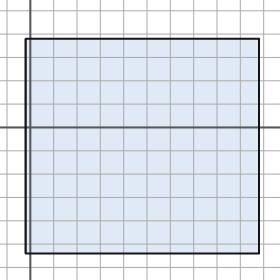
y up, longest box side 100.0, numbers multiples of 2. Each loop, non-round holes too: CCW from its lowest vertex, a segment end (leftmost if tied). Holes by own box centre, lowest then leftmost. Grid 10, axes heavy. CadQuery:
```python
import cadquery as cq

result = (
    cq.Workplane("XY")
    .moveTo(-2.0, -54.0)
    .lineTo(98.0, -54.0)
    .lineTo(98.0, 38.0)
    .lineTo(-2.0, 38.0)
    .close()
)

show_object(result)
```